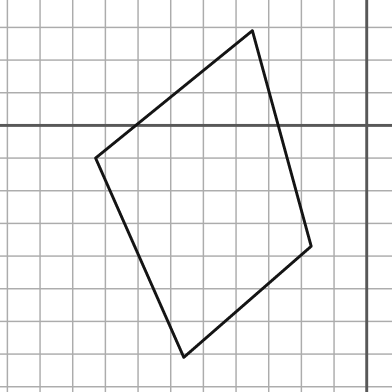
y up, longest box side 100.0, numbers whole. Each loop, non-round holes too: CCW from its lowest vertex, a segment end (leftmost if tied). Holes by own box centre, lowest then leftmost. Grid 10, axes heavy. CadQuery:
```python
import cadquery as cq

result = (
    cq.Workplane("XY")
    .moveTo(-56.0, -71.0)
    .lineTo(-17.0, -37.0)
    .lineTo(-35.0, 29.0)
    .lineTo(-83.0, -10.0)
    .close()
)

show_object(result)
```